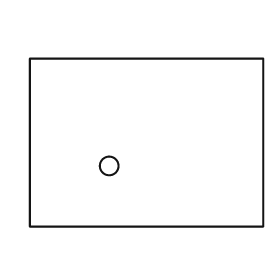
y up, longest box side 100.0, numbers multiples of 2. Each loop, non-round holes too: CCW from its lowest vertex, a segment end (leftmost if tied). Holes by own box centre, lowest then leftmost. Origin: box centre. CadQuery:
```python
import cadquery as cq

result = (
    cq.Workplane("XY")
    .moveTo(-50.0, -36.0)
    .lineTo(50.0, -36.0)
    .lineTo(50.0, 36.0)
    .lineTo(-50.0, 36.0)
    .close()
    .moveTo(-16.0, -10.0)
    .circle(4.0)
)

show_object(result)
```